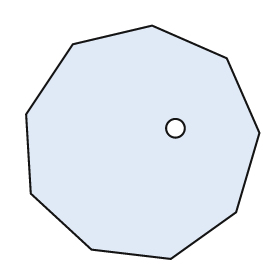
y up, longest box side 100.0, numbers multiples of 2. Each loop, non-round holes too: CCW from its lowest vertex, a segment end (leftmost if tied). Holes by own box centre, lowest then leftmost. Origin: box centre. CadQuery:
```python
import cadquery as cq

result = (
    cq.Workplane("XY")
    .moveTo(12.0, -50.0)
    .lineTo(40.0, -30.0)
    .lineTo(50.0, 4.0)
    .lineTo(36.0, 36.0)
    .lineTo(4.0, 50.0)
    .lineTo(-30.0, 42.0)
    .lineTo(-50.0, 12.0)
    .lineTo(-48.0, -22.0)
    .lineTo(-22.0, -46.0)
    .close()
    .moveTo(14.0, 6.0)
    .circle(4.0)
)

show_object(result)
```